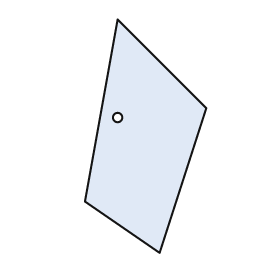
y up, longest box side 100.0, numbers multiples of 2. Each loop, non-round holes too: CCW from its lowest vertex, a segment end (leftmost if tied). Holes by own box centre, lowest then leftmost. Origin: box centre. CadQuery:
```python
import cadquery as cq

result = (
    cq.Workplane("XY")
    .moveTo(6.0, -50.0)
    .lineTo(26.0, 12.0)
    .lineTo(-12.0, 50.0)
    .lineTo(-26.0, -28.0)
    .close()
    .moveTo(-12.0, 8.0)
    .circle(2.0)
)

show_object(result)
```